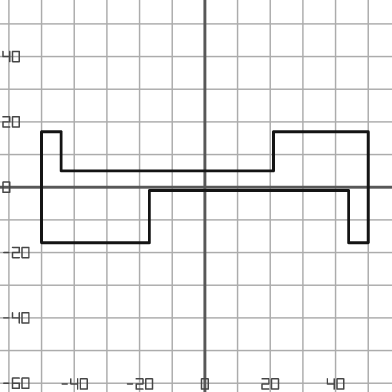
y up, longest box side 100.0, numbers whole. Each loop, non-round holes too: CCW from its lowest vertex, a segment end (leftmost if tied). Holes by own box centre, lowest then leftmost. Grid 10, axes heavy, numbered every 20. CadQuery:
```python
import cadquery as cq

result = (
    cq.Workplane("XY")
    .moveTo(-50.0, -17.0)
    .lineTo(-17.0, -17.0)
    .lineTo(-17.0, -1.0)
    .lineTo(44.0, -1.0)
    .lineTo(44.0, -17.0)
    .lineTo(50.0, -17.0)
    .lineTo(50.0, 17.0)
    .lineTo(21.0, 17.0)
    .lineTo(21.0, 5.0)
    .lineTo(-44.0, 5.0)
    .lineTo(-44.0, 17.0)
    .lineTo(-50.0, 17.0)
    .close()
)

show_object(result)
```